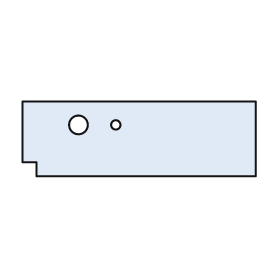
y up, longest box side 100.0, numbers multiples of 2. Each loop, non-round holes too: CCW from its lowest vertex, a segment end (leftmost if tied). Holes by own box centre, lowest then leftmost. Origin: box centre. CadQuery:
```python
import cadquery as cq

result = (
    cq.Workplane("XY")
    .moveTo(-44.0, -16.0)
    .lineTo(50.0, -16.0)
    .lineTo(50.0, 16.0)
    .lineTo(-50.0, 16.0)
    .lineTo(-50.0, -10.0)
    .lineTo(-44.0, -10.0)
    .close()
    .moveTo(-26.0, 6.0)
    .circle(4.0)
    .moveTo(-10.0, 6.0)
    .circle(2.0)
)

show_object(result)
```